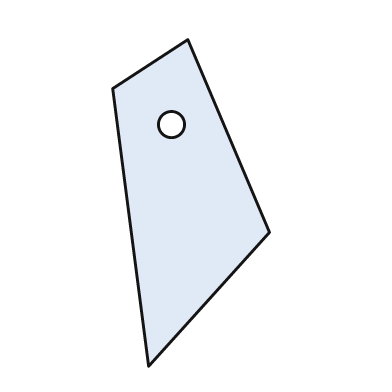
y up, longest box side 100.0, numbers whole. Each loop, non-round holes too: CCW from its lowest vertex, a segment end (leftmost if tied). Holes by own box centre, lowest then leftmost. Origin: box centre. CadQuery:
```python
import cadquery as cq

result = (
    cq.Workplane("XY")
    .moveTo(-13.0, -50.0)
    .lineTo(24.0, -9.0)
    .lineTo(-1.0, 50.0)
    .lineTo(-24.0, 35.0)
    .close()
    .moveTo(-6.0, 24.0)
    .circle(4.0)
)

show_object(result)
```